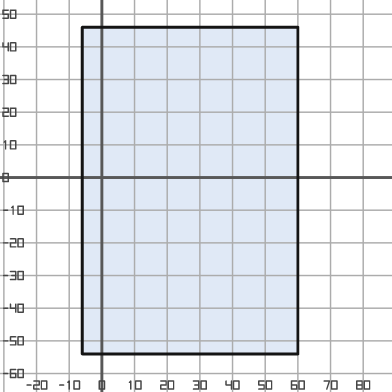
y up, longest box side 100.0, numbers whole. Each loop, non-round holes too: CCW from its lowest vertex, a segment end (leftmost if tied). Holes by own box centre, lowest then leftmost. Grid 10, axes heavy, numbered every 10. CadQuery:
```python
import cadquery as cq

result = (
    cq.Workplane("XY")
    .moveTo(-6.0, -54.0)
    .lineTo(60.0, -54.0)
    .lineTo(60.0, 46.0)
    .lineTo(-6.0, 46.0)
    .close()
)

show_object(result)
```